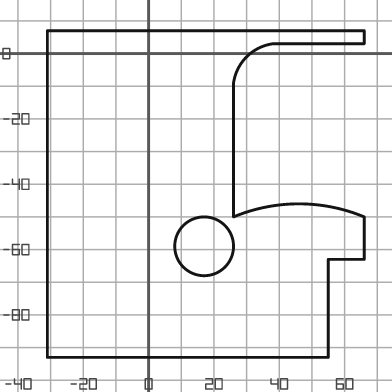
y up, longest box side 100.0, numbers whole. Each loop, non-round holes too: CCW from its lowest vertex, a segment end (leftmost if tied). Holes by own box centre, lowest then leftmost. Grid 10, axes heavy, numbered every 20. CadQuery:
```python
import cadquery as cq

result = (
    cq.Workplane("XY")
    .moveTo(-31.0, -93.0)
    .lineTo(55.0, -93.0)
    .lineTo(55.0, -63.0)
    .lineTo(66.0, -63.0)
    .lineTo(66.0, -50.0)
    .threePointArc((46.0, -46.0), (26.0, -50.0))
    .lineTo(26.0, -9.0)
    .threePointArc((30.0, -1.0), (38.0, 3.0))
    .lineTo(66.0, 3.0)
    .lineTo(66.0, 7.0)
    .lineTo(-31.0, 7.0)
    .close()
    .moveTo(17.0, -59.0)
    .circle(9.0)
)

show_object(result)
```